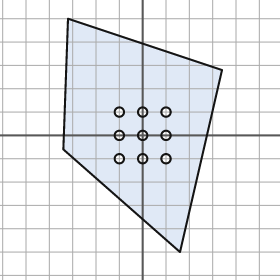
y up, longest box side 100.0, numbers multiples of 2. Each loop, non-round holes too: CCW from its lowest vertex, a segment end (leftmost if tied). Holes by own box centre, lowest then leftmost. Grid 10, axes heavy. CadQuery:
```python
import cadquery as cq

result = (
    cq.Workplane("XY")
    .moveTo(16.0, -50.0)
    .lineTo(34.0, 28.0)
    .lineTo(-32.0, 50.0)
    .lineTo(-34.0, -6.0)
    .close()
    .moveTo(-10.0, -10.0)
    .circle(2.0)
    .moveTo(0.0, -10.0)
    .circle(2.0)
    .moveTo(10.0, -10.0)
    .circle(2.0)
    .moveTo(-10.0, 0.0)
    .circle(2.0)
    .moveTo(0.0, 0.0)
    .circle(2.0)
    .moveTo(10.0, 0.0)
    .circle(2.0)
    .moveTo(-10.0, 10.0)
    .circle(2.0)
    .moveTo(0.0, 10.0)
    .circle(2.0)
    .moveTo(10.0, 10.0)
    .circle(2.0)
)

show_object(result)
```